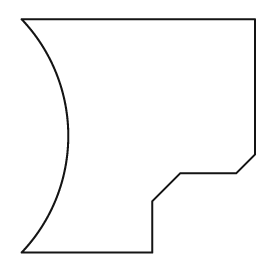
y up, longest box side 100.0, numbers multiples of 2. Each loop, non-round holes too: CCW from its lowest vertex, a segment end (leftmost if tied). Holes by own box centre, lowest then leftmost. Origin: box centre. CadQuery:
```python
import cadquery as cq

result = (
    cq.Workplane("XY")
    .moveTo(-50.0, -50.0)
    .lineTo(6.0, -50.0)
    .lineTo(6.0, -28.0)
    .lineTo(18.0, -16.0)
    .lineTo(42.0, -16.0)
    .lineTo(50.0, -8.0)
    .lineTo(50.0, 50.0)
    .lineTo(-50.0, 50.0)
    .threePointArc((-30.0, 0.0), (-50.0, -50.0))
    .close()
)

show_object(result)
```